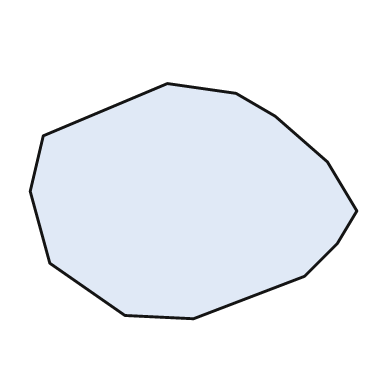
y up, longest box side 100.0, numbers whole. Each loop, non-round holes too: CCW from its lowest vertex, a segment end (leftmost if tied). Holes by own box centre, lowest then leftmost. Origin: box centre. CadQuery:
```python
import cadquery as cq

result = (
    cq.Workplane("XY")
    .moveTo(0.0, -36.0)
    .lineTo(34.0, -23.0)
    .lineTo(44.0, -13.0)
    .lineTo(50.0, -3.0)
    .lineTo(41.0, 12.0)
    .lineTo(25.0, 26.0)
    .lineTo(13.0, 33.0)
    .lineTo(-8.0, 36.0)
    .lineTo(-46.0, 20.0)
    .lineTo(-50.0, 3.0)
    .lineTo(-44.0, -19.0)
    .lineTo(-21.0, -35.0)
    .close()
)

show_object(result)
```